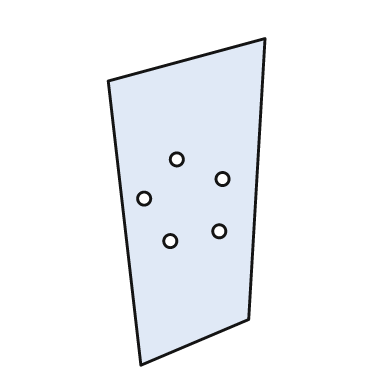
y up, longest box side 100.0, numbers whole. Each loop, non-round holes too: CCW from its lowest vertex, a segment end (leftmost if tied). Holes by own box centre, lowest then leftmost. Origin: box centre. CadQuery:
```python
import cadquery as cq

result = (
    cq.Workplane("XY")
    .moveTo(-14.0, -50.0)
    .lineTo(19.0, -36.0)
    .lineTo(24.0, 50.0)
    .lineTo(-24.0, 37.0)
    .close()
    .moveTo(-5.0, -12.0)
    .circle(2.0)
    .moveTo(10.0, -9.0)
    .circle(2.0)
    .moveTo(-13.0, 1.0)
    .circle(2.0)
    .moveTo(11.0, 7.0)
    .circle(2.0)
    .moveTo(-3.0, 13.0)
    .circle(2.0)
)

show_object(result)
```